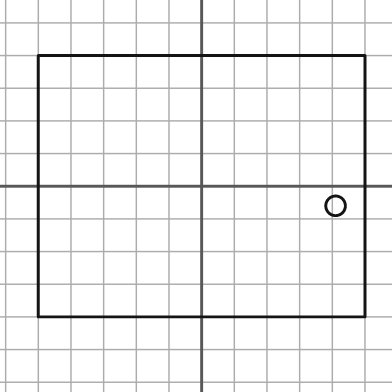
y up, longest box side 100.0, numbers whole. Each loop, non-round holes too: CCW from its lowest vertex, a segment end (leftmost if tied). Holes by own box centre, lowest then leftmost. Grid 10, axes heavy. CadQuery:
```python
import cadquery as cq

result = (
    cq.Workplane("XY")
    .moveTo(-50.0, -40.0)
    .lineTo(50.0, -40.0)
    .lineTo(50.0, 40.0)
    .lineTo(-50.0, 40.0)
    .close()
    .moveTo(41.0, -6.0)
    .circle(3.0)
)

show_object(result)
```